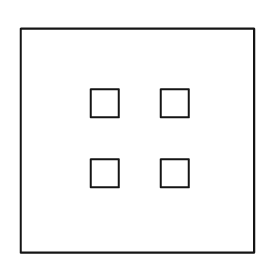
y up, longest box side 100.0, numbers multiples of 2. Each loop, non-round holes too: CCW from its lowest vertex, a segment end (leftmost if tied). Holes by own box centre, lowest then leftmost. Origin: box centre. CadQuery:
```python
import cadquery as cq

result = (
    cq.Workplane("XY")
    .moveTo(-50.0, -48.0)
    .lineTo(50.0, -48.0)
    .lineTo(50.0, 48.0)
    .lineTo(-50.0, 48.0)
    .close()
    .moveTo(-20.0, -20.0)
    .lineTo(-8.0, -20.0)
    .lineTo(-8.0, -8.0)
    .lineTo(-20.0, -8.0)
    .close()
    .moveTo(10.0, -20.0)
    .lineTo(22.0, -20.0)
    .lineTo(22.0, -8.0)
    .lineTo(10.0, -8.0)
    .close()
    .moveTo(-20.0, 10.0)
    .lineTo(-8.0, 10.0)
    .lineTo(-8.0, 22.0)
    .lineTo(-20.0, 22.0)
    .close()
    .moveTo(10.0, 10.0)
    .lineTo(22.0, 10.0)
    .lineTo(22.0, 22.0)
    .lineTo(10.0, 22.0)
    .close()
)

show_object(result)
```